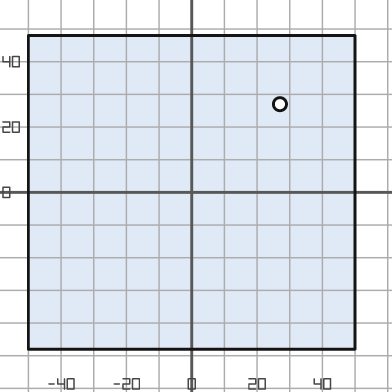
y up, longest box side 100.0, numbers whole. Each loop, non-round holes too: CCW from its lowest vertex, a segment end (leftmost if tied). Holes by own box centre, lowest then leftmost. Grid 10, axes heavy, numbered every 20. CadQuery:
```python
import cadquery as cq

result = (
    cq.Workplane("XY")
    .moveTo(-50.0, -48.0)
    .lineTo(50.0, -48.0)
    .lineTo(50.0, 48.0)
    .lineTo(-50.0, 48.0)
    .close()
    .moveTo(27.0, 27.0)
    .circle(2.0)
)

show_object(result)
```